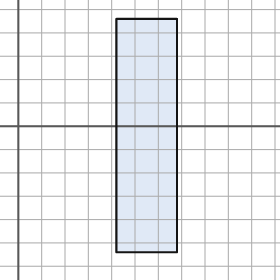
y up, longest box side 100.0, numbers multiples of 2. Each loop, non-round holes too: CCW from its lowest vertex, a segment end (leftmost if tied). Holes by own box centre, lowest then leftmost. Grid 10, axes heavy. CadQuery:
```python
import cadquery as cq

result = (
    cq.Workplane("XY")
    .moveTo(42.0, -54.0)
    .lineTo(68.0, -54.0)
    .lineTo(68.0, 46.0)
    .lineTo(42.0, 46.0)
    .close()
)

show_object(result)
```